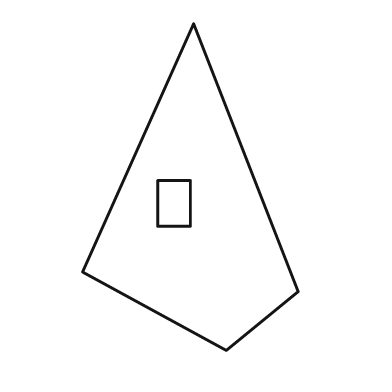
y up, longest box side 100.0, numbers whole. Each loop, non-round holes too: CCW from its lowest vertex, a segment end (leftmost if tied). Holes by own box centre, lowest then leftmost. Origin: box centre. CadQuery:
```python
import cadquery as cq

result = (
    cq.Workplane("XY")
    .moveTo(11.0, -50.0)
    .lineTo(33.0, -32.0)
    .lineTo(1.0, 50.0)
    .lineTo(-33.0, -26.0)
    .close()
    .moveTo(-10.0, -12.0)
    .lineTo(0.0, -12.0)
    .lineTo(0.0, 2.0)
    .lineTo(-10.0, 2.0)
    .close()
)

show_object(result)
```